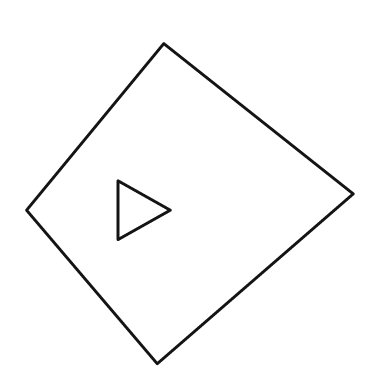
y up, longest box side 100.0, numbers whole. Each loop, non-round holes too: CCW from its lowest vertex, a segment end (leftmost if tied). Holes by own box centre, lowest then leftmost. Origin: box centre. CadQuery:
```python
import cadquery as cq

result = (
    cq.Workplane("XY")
    .moveTo(-10.0, -49.0)
    .lineTo(50.0, 3.0)
    .lineTo(-8.0, 49.0)
    .lineTo(-50.0, -2.0)
    .close()
    .moveTo(-22.0, -11.0)
    .lineTo(-6.0, -2.0)
    .lineTo(-22.0, 7.0)
    .close()
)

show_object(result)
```